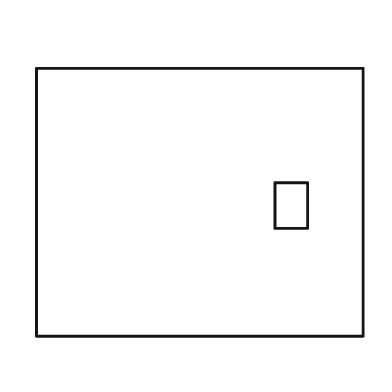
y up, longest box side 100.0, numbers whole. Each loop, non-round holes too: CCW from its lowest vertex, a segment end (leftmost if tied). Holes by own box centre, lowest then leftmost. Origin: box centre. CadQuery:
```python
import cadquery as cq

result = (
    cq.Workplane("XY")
    .moveTo(-50.0, -41.0)
    .lineTo(50.0, -41.0)
    .lineTo(50.0, 41.0)
    .lineTo(-50.0, 41.0)
    .close()
    .moveTo(23.0, -8.0)
    .lineTo(33.0, -8.0)
    .lineTo(33.0, 6.0)
    .lineTo(23.0, 6.0)
    .close()
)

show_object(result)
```